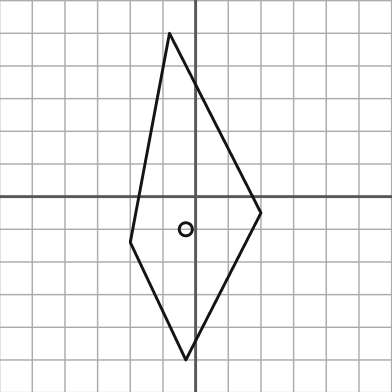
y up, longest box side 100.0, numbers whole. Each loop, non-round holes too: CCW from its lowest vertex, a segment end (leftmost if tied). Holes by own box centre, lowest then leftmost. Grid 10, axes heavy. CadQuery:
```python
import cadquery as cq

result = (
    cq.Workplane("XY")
    .moveTo(-3.0, -50.0)
    .lineTo(20.0, -5.0)
    .lineTo(-8.0, 50.0)
    .lineTo(-20.0, -14.0)
    .close()
    .moveTo(-3.0, -10.0)
    .circle(2.0)
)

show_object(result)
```